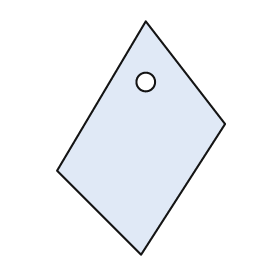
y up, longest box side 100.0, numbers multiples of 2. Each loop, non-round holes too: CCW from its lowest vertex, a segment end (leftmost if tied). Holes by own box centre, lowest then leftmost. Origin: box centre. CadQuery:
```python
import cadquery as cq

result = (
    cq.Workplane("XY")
    .moveTo(0.0, -50.0)
    .lineTo(36.0, 6.0)
    .lineTo(2.0, 50.0)
    .lineTo(-36.0, -14.0)
    .close()
    .moveTo(2.0, 24.0)
    .circle(4.0)
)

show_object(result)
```